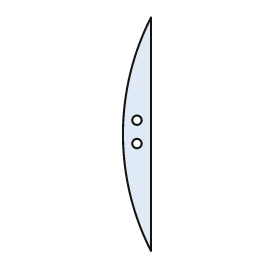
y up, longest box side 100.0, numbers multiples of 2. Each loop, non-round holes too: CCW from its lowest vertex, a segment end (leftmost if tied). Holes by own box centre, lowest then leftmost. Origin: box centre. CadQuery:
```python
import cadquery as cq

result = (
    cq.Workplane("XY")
    .moveTo(6.0, -50.0)
    .lineTo(6.0, 50.0)
    .threePointArc((-6.0, 0.0), (6.0, -50.0))
    .close()
    .moveTo(0.0, -4.0)
    .circle(2.0)
    .moveTo(0.0, 6.0)
    .circle(2.0)
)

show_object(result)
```